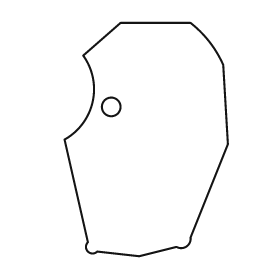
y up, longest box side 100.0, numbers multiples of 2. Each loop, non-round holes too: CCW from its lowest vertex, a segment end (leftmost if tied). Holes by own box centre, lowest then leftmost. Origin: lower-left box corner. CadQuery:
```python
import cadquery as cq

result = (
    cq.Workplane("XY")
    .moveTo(32.0, 0.0)
    .lineTo(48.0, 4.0)
    .threePointArc((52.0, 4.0), (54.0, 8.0))
    .lineTo(70.0, 48.0)
    .lineTo(68.0, 82.0)
    .threePointArc((62.0, 92.0), (54.0, 100.0))
    .lineTo(24.0, 100.0)
    .lineTo(8.0, 86.0)
    .threePointArc((12.0, 66.0), (0.0, 50.0))
    .lineTo(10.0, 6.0)
    .threePointArc((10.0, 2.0), (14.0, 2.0))
    .close()
    .moveTo(20.0, 64.0)
    .circle(4.0)
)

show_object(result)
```